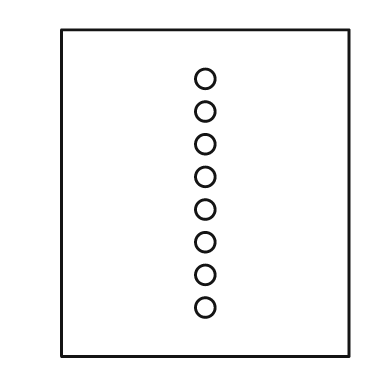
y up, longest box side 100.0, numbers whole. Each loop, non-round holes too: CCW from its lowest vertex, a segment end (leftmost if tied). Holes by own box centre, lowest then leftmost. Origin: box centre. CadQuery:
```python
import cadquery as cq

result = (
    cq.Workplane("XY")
    .moveTo(-44.0, -50.0)
    .lineTo(44.0, -50.0)
    .lineTo(44.0, 50.0)
    .lineTo(-44.0, 50.0)
    .close()
    .moveTo(0.0, -35.0)
    .circle(3.0)
    .moveTo(0.0, -25.0)
    .circle(3.0)
    .moveTo(0.0, -15.0)
    .circle(3.0)
    .moveTo(0.0, -5.0)
    .circle(3.0)
    .moveTo(0.0, 5.0)
    .circle(3.0)
    .moveTo(0.0, 15.0)
    .circle(3.0)
    .moveTo(0.0, 25.0)
    .circle(3.0)
    .moveTo(0.0, 35.0)
    .circle(3.0)
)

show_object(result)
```